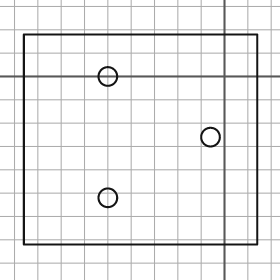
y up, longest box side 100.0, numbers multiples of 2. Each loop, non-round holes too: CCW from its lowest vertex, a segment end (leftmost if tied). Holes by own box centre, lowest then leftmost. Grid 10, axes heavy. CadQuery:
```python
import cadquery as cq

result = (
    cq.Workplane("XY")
    .moveTo(-86.0, -72.0)
    .lineTo(14.0, -72.0)
    .lineTo(14.0, 18.0)
    .lineTo(-86.0, 18.0)
    .close()
    .moveTo(-50.0, -52.0)
    .circle(4.0)
    .moveTo(-6.0, -26.0)
    .circle(4.0)
    .moveTo(-50.0, 0.0)
    .circle(4.0)
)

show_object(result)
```